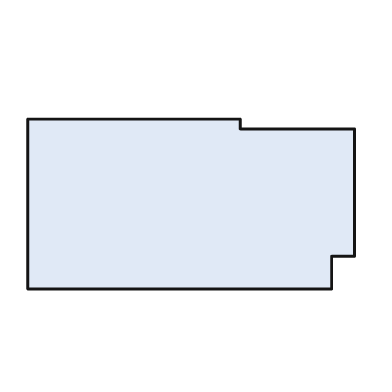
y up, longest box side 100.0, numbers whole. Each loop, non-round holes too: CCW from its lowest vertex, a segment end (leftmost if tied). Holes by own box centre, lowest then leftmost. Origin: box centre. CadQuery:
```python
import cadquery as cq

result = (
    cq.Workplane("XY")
    .moveTo(-50.0, -26.0)
    .lineTo(43.0, -26.0)
    .lineTo(43.0, -16.0)
    .lineTo(50.0, -16.0)
    .lineTo(50.0, 23.0)
    .lineTo(15.0, 23.0)
    .lineTo(15.0, 26.0)
    .lineTo(-50.0, 26.0)
    .close()
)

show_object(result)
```